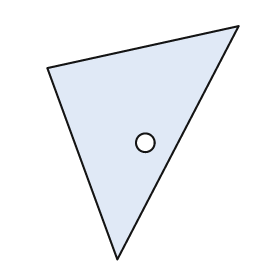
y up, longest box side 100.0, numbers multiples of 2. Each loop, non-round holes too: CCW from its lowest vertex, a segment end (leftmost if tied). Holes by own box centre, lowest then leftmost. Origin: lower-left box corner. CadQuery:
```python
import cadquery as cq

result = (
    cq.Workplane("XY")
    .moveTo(30.0, 0.0)
    .lineTo(82.0, 100.0)
    .lineTo(0.0, 82.0)
    .close()
    .moveTo(42.0, 50.0)
    .circle(4.0)
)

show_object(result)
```